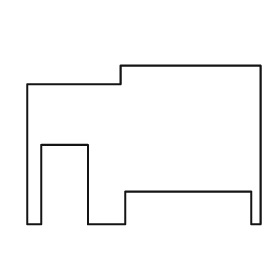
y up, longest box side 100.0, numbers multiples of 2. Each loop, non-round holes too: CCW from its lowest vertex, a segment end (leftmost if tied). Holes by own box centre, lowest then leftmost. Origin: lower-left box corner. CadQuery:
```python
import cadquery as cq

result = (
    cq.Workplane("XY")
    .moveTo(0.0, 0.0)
    .lineTo(6.0, 0.0)
    .lineTo(6.0, 34.0)
    .lineTo(26.0, 34.0)
    .lineTo(26.0, 0.0)
    .lineTo(42.0, 0.0)
    .lineTo(42.0, 14.0)
    .lineTo(96.0, 14.0)
    .lineTo(96.0, 0.0)
    .lineTo(100.0, 0.0)
    .lineTo(100.0, 68.0)
    .lineTo(40.0, 68.0)
    .lineTo(40.0, 60.0)
    .lineTo(0.0, 60.0)
    .close()
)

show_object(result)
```